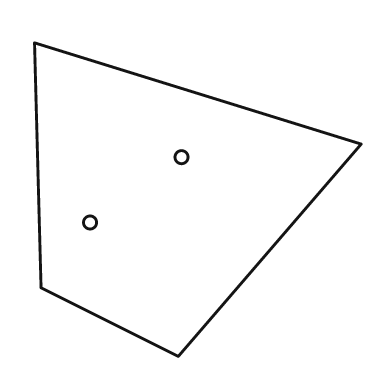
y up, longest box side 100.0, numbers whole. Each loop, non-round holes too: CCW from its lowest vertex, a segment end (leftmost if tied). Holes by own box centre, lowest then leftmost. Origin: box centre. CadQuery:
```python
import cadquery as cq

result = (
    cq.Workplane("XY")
    .moveTo(-6.0, -48.0)
    .lineTo(50.0, 17.0)
    .lineTo(-50.0, 48.0)
    .lineTo(-48.0, -27.0)
    .close()
    .moveTo(-33.0, -7.0)
    .circle(2.0)
    .moveTo(-5.0, 13.0)
    .circle(2.0)
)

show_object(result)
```